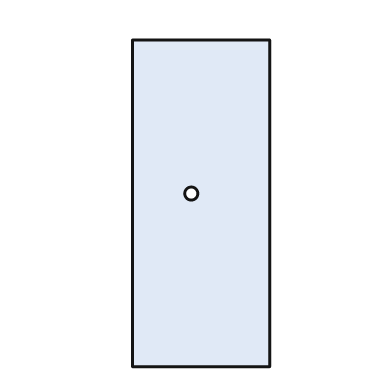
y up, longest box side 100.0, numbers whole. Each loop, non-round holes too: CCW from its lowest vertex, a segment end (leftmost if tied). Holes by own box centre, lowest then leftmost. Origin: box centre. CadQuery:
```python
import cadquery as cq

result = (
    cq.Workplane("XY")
    .moveTo(-21.0, -50.0)
    .lineTo(21.0, -50.0)
    .lineTo(21.0, 50.0)
    .lineTo(-21.0, 50.0)
    .close()
    .moveTo(-3.0, 3.0)
    .circle(2.0)
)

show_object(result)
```